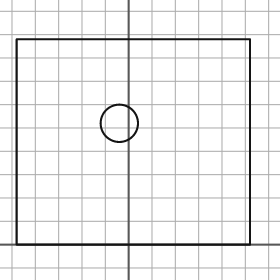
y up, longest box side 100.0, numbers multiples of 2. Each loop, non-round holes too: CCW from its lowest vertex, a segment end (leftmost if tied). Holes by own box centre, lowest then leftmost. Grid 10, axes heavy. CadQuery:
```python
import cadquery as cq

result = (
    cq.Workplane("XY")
    .moveTo(-48.0, 0.0)
    .lineTo(52.0, 0.0)
    .lineTo(52.0, 88.0)
    .lineTo(-48.0, 88.0)
    .close()
    .moveTo(-4.0, 52.0)
    .circle(8.0)
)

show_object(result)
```